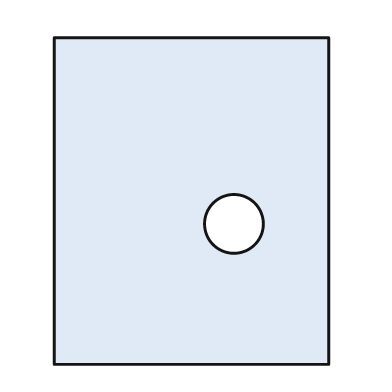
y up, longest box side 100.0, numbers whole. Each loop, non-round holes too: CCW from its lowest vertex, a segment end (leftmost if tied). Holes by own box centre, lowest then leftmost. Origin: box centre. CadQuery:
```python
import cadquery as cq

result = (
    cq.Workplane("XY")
    .moveTo(-42.0, -50.0)
    .lineTo(42.0, -50.0)
    .lineTo(42.0, 50.0)
    .lineTo(-42.0, 50.0)
    .close()
    .moveTo(13.0, -7.0)
    .circle(9.0)
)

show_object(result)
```